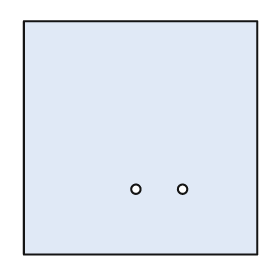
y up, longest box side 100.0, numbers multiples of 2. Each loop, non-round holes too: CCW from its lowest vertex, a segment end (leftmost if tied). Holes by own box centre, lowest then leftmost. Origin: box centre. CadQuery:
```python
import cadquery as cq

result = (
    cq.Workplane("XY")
    .moveTo(-50.0, -50.0)
    .lineTo(50.0, -50.0)
    .lineTo(50.0, 50.0)
    .lineTo(-50.0, 50.0)
    .close()
    .moveTo(-2.0, -22.0)
    .circle(2.0)
    .moveTo(18.0, -22.0)
    .circle(2.0)
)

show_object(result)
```